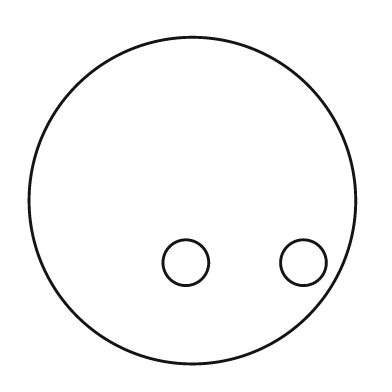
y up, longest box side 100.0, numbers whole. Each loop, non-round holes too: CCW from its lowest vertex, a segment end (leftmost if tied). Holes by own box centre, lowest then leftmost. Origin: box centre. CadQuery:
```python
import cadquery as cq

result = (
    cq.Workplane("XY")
    .moveTo(0.0, 0.0)
    .circle(50.0)
    .moveTo(-2.0, -19.0)
    .circle(7.0)
    .moveTo(34.0, -19.0)
    .circle(7.0)
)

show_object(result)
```